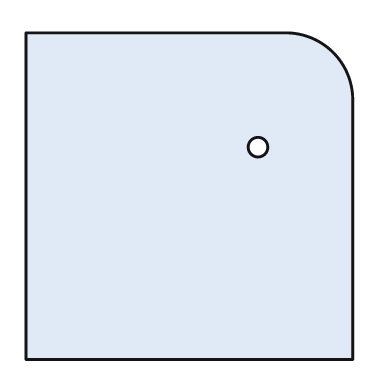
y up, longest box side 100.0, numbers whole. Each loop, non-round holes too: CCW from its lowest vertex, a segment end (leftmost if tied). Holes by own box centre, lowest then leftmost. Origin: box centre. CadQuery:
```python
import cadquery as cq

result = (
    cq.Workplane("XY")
    .moveTo(-50.0, -50.0)
    .lineTo(50.0, -50.0)
    .lineTo(50.0, 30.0)
    .threePointArc((44.0, 44.0), (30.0, 50.0))
    .lineTo(-50.0, 50.0)
    .close()
    .moveTo(21.0, 15.0)
    .circle(3.0)
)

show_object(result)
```